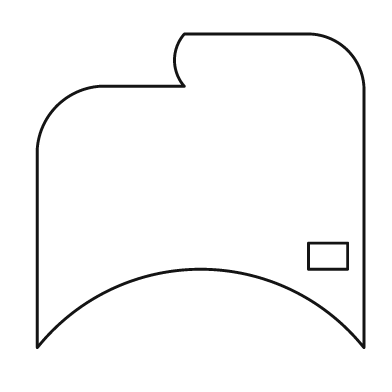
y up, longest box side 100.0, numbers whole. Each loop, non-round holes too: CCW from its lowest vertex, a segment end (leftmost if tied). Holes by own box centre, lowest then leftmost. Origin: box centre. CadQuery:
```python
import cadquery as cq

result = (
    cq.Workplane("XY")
    .moveTo(-50.0, -48.0)
    .threePointArc((0.0, -24.0), (50.0, -48.0))
    .lineTo(50.0, 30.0)
    .threePointArc((45.0, 43.0), (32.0, 48.0))
    .lineTo(-5.0, 48.0)
    .threePointArc((-8.0, 40.0), (-5.0, 32.0))
    .lineTo(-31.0, 32.0)
    .threePointArc((-44.0, 26.0), (-50.0, 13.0))
    .close()
    .moveTo(33.0, -24.0)
    .lineTo(45.0, -24.0)
    .lineTo(45.0, -16.0)
    .lineTo(33.0, -16.0)
    .close()
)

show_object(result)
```